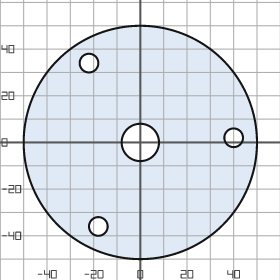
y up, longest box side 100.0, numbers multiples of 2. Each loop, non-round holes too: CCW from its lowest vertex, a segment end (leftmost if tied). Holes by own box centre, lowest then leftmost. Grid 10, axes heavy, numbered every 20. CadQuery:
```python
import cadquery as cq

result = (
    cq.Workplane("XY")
    .moveTo(0.0, 0.0)
    .circle(50.0)
    .moveTo(-18.0, -36.0)
    .circle(4.0)
    .moveTo(0.0, 0.0)
    .circle(8.0)
    .moveTo(40.0, 2.0)
    .circle(4.0)
    .moveTo(-22.0, 34.0)
    .circle(4.0)
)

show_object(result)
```